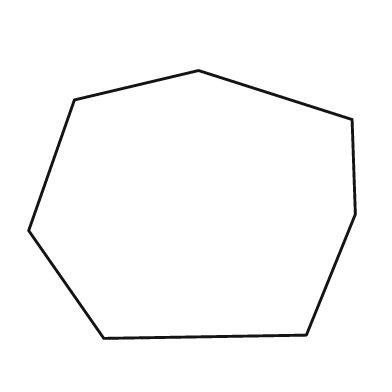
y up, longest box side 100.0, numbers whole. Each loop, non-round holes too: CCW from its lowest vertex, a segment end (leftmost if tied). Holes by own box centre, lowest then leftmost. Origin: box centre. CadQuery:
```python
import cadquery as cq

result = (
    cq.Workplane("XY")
    .moveTo(-27.0, -41.0)
    .lineTo(35.0, -40.0)
    .lineTo(50.0, -3.0)
    .lineTo(49.0, 26.0)
    .lineTo(2.0, 41.0)
    .lineTo(-36.0, 32.0)
    .lineTo(-50.0, -8.0)
    .close()
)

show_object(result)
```